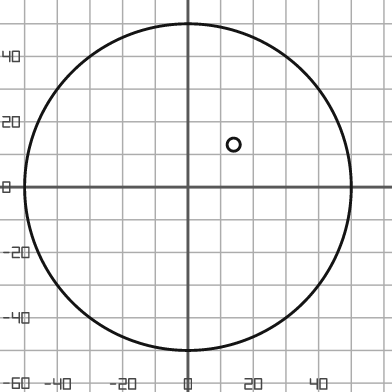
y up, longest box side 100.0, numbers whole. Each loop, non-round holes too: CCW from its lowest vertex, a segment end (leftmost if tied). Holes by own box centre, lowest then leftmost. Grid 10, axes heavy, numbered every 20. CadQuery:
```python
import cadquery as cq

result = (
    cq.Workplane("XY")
    .moveTo(0.0, 0.0)
    .circle(50.0)
    .moveTo(14.0, 13.0)
    .circle(2.0)
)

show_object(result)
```